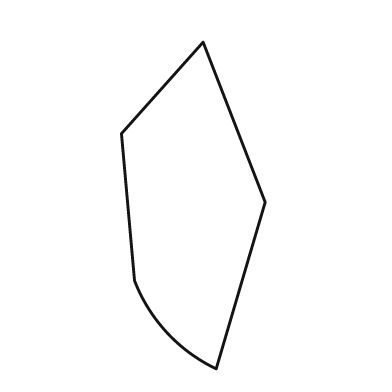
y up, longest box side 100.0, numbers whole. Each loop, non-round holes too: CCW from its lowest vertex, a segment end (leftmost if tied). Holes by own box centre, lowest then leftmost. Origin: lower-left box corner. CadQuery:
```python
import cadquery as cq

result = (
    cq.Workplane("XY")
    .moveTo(29.0, 0.0)
    .lineTo(44.0, 51.0)
    .lineTo(25.0, 100.0)
    .lineTo(0.0, 72.0)
    .lineTo(4.0, 27.0)
    .threePointArc((14.0, 11.0), (29.0, 0.0))
    .close()
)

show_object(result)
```